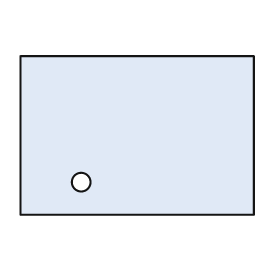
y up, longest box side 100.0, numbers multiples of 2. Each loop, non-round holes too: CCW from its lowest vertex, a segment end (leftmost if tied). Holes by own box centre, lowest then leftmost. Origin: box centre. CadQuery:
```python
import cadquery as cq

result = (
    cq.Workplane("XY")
    .moveTo(-50.0, -34.0)
    .lineTo(50.0, -34.0)
    .lineTo(50.0, 34.0)
    .lineTo(-50.0, 34.0)
    .close()
    .moveTo(-24.0, -20.0)
    .circle(4.0)
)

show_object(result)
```